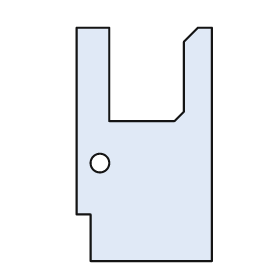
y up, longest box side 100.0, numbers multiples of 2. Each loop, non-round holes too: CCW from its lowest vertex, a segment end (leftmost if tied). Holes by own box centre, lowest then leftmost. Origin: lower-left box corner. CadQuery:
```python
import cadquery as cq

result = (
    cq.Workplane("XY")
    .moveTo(6.0, 0.0)
    .lineTo(58.0, 0.0)
    .lineTo(58.0, 100.0)
    .lineTo(52.0, 100.0)
    .lineTo(46.0, 94.0)
    .lineTo(46.0, 64.0)
    .lineTo(42.0, 60.0)
    .lineTo(14.0, 60.0)
    .lineTo(14.0, 100.0)
    .lineTo(0.0, 100.0)
    .lineTo(0.0, 20.0)
    .lineTo(6.0, 20.0)
    .close()
    .moveTo(10.0, 42.0)
    .circle(4.0)
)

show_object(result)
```